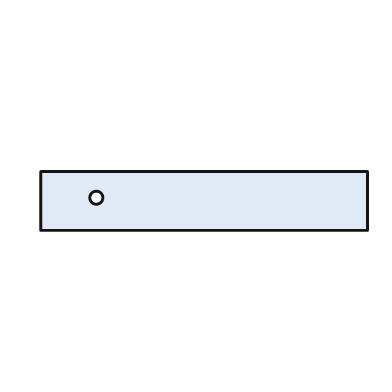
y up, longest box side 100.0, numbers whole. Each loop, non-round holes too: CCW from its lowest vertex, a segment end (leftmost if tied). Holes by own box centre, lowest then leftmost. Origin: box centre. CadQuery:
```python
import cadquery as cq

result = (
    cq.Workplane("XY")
    .moveTo(-50.0, -9.0)
    .lineTo(50.0, -9.0)
    .lineTo(50.0, 9.0)
    .lineTo(-50.0, 9.0)
    .close()
    .moveTo(-33.0, 1.0)
    .circle(2.0)
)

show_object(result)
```